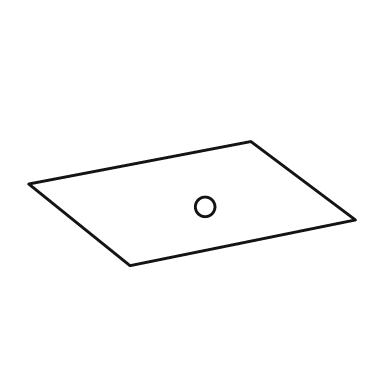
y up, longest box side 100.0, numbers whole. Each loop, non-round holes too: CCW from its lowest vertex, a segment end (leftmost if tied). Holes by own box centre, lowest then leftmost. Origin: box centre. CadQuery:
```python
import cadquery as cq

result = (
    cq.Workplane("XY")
    .moveTo(-19.0, -19.0)
    .lineTo(50.0, -5.0)
    .lineTo(18.0, 19.0)
    .lineTo(-50.0, 6.0)
    .close()
    .moveTo(4.0, -1.0)
    .circle(3.0)
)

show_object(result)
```